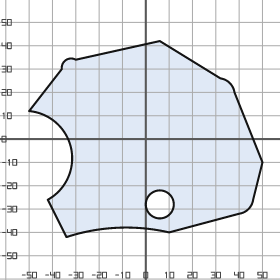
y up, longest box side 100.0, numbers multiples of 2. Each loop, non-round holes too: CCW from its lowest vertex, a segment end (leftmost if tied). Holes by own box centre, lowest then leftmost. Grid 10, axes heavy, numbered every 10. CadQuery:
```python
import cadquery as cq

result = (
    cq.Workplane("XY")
    .moveTo(-34.0, -42.0)
    .threePointArc((-12.0, -38.0), (10.0, -40.0))
    .lineTo(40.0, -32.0)
    .threePointArc((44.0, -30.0), (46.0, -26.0))
    .lineTo(50.0, -10.0)
    .lineTo(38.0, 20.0)
    .threePointArc((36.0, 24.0), (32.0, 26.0))
    .lineTo(6.0, 42.0)
    .lineTo(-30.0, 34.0)
    .threePointArc((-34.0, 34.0), (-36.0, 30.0))
    .lineTo(-50.0, 12.0)
    .threePointArc((-32.0, -4.0), (-42.0, -26.0))
    .close()
    .moveTo(6.0, -28.0)
    .circle(6.0)
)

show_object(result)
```